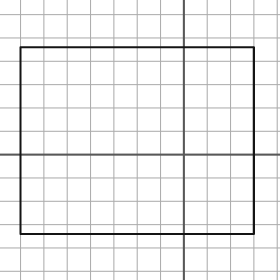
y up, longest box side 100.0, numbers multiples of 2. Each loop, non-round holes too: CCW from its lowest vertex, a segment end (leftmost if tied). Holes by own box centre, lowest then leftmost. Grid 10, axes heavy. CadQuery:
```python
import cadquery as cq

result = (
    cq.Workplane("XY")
    .moveTo(-70.0, -34.0)
    .lineTo(30.0, -34.0)
    .lineTo(30.0, 46.0)
    .lineTo(-70.0, 46.0)
    .close()
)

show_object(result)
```